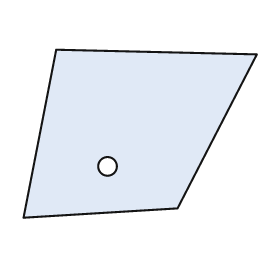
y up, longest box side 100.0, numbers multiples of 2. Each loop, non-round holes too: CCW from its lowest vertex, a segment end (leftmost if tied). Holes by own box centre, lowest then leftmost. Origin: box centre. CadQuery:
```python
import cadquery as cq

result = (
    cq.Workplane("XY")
    .moveTo(-50.0, -36.0)
    .lineTo(16.0, -32.0)
    .lineTo(50.0, 34.0)
    .lineTo(-36.0, 36.0)
    .close()
    .moveTo(-14.0, -14.0)
    .circle(4.0)
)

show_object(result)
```